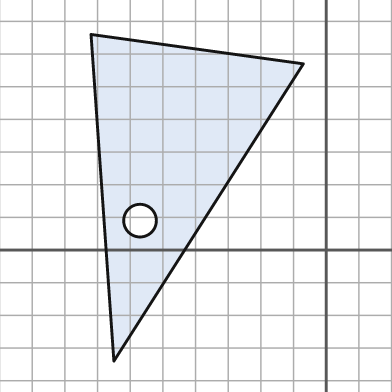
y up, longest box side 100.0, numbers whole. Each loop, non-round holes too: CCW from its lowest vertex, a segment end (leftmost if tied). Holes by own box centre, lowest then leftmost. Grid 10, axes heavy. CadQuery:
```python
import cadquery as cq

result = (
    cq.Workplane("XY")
    .moveTo(-65.0, -34.0)
    .lineTo(-7.0, 57.0)
    .lineTo(-72.0, 66.0)
    .close()
    .moveTo(-57.0, 9.0)
    .circle(5.0)
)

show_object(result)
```